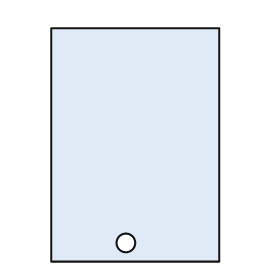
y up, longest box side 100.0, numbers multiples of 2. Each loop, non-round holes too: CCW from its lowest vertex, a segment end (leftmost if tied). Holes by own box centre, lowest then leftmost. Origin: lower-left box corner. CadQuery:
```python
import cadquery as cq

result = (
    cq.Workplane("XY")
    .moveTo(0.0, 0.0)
    .lineTo(72.0, 0.0)
    .lineTo(72.0, 100.0)
    .lineTo(0.0, 100.0)
    .close()
    .moveTo(32.0, 8.0)
    .circle(4.0)
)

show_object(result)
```